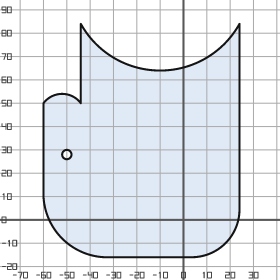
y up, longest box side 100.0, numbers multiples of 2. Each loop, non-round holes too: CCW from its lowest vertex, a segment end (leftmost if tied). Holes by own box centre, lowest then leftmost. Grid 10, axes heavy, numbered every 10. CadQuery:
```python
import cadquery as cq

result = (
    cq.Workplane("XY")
    .moveTo(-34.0, -16.0)
    .lineTo(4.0, -16.0)
    .threePointArc((18.0, -10.0), (24.0, 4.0))
    .lineTo(24.0, 84.0)
    .threePointArc((-10.0, 64.0), (-44.0, 84.0))
    .lineTo(-44.0, 50.0)
    .threePointArc((-52.0, 54.0), (-60.0, 50.0))
    .lineTo(-60.0, 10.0)
    .threePointArc((-52.0, -8.0), (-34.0, -16.0))
    .close()
    .moveTo(-50.0, 28.0)
    .circle(2.0)
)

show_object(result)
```